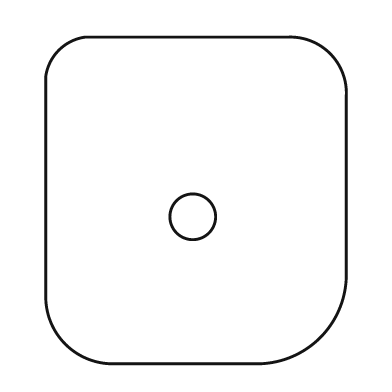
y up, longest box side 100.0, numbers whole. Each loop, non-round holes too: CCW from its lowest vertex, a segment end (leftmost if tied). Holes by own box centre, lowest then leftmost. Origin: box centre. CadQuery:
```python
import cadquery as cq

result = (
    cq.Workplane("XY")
    .moveTo(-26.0, -50.0)
    .lineTo(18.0, -50.0)
    .threePointArc((38.0, -42.0), (46.0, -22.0))
    .lineTo(46.0, 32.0)
    .threePointArc((41.0, 45.0), (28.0, 50.0))
    .lineTo(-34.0, 50.0)
    .threePointArc((-42.0, 46.0), (-46.0, 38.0))
    .lineTo(-46.0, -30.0)
    .threePointArc((-40.0, -44.0), (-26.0, -50.0))
    .close()
    .moveTo(-1.0, -5.0)
    .circle(7.0)
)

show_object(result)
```